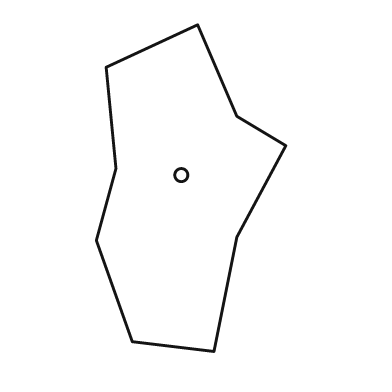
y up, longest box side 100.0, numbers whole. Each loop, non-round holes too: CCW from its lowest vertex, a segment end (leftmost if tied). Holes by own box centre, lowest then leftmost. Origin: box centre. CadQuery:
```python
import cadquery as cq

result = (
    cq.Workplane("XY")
    .moveTo(7.0, -50.0)
    .lineTo(14.0, -15.0)
    .lineTo(29.0, 13.0)
    .lineTo(14.0, 22.0)
    .lineTo(2.0, 50.0)
    .lineTo(-26.0, 37.0)
    .lineTo(-23.0, 6.0)
    .lineTo(-29.0, -16.0)
    .lineTo(-18.0, -47.0)
    .close()
    .moveTo(-3.0, 4.0)
    .circle(2.0)
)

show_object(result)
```